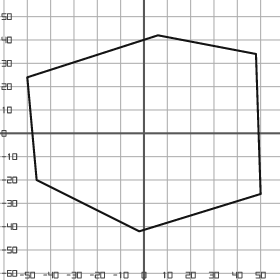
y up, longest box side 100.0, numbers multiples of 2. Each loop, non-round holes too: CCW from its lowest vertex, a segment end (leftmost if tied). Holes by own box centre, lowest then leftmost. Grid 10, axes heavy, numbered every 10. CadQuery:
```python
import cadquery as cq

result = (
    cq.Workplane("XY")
    .moveTo(-2.0, -42.0)
    .lineTo(50.0, -26.0)
    .lineTo(48.0, 34.0)
    .lineTo(6.0, 42.0)
    .lineTo(-50.0, 24.0)
    .lineTo(-46.0, -20.0)
    .close()
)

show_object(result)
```